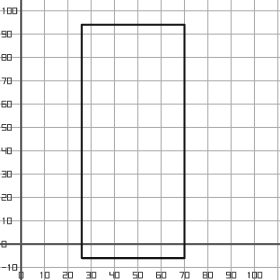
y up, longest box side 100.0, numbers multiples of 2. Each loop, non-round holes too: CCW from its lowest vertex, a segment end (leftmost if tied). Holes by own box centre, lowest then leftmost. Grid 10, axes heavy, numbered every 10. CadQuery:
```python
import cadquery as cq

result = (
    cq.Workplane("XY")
    .moveTo(26.0, -6.0)
    .lineTo(70.0, -6.0)
    .lineTo(70.0, 94.0)
    .lineTo(26.0, 94.0)
    .close()
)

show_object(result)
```